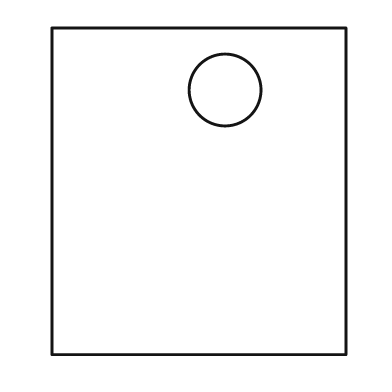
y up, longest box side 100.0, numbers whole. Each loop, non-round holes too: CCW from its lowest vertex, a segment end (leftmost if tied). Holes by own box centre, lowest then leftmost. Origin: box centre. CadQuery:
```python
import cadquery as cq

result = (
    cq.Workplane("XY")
    .moveTo(-45.0, -50.0)
    .lineTo(45.0, -50.0)
    .lineTo(45.0, 50.0)
    .lineTo(-45.0, 50.0)
    .close()
    .moveTo(8.0, 31.0)
    .circle(11.0)
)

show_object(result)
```